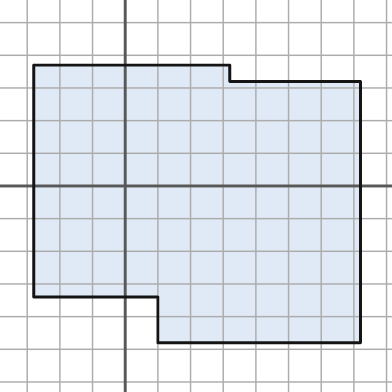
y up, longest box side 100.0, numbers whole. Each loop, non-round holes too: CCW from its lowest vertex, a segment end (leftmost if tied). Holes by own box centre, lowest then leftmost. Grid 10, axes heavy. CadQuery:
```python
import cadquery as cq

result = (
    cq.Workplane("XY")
    .moveTo(10.0, -48.0)
    .lineTo(72.0, -48.0)
    .lineTo(72.0, 32.0)
    .lineTo(32.0, 32.0)
    .lineTo(32.0, 37.0)
    .lineTo(-28.0, 37.0)
    .lineTo(-28.0, -34.0)
    .lineTo(10.0, -34.0)
    .close()
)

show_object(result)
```